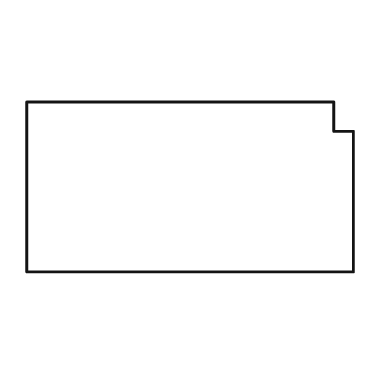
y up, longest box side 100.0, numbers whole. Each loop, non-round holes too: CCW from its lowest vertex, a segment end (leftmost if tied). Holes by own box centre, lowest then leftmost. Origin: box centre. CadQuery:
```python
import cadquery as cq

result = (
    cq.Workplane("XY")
    .moveTo(-50.0, -26.0)
    .lineTo(50.0, -26.0)
    .lineTo(50.0, 17.0)
    .lineTo(44.0, 17.0)
    .lineTo(44.0, 26.0)
    .lineTo(-50.0, 26.0)
    .close()
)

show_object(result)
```